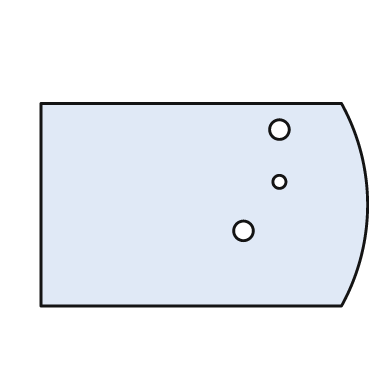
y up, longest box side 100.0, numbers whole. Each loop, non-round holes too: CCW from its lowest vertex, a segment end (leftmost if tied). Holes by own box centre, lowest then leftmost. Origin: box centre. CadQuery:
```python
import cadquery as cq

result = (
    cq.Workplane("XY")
    .moveTo(-50.0, -31.0)
    .lineTo(42.0, -31.0)
    .threePointArc((50.0, 0.0), (42.0, 31.0))
    .lineTo(-50.0, 31.0)
    .close()
    .moveTo(12.0, -8.0)
    .circle(3.0)
    .moveTo(23.0, 7.0)
    .circle(2.0)
    .moveTo(23.0, 23.0)
    .circle(3.0)
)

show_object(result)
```